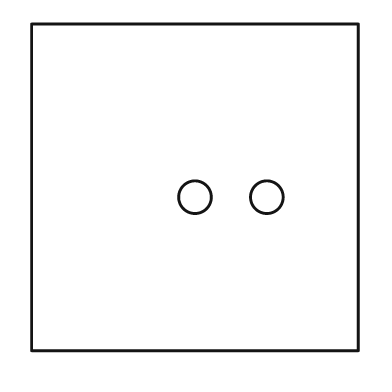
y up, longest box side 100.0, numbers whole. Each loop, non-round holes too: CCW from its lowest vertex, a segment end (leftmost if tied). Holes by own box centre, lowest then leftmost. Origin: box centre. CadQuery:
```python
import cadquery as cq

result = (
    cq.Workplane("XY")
    .moveTo(-50.0, -50.0)
    .lineTo(50.0, -50.0)
    .lineTo(50.0, 50.0)
    .lineTo(-50.0, 50.0)
    .close()
    .moveTo(0.0, -3.0)
    .circle(5.0)
    .moveTo(22.0, -3.0)
    .circle(5.0)
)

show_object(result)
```